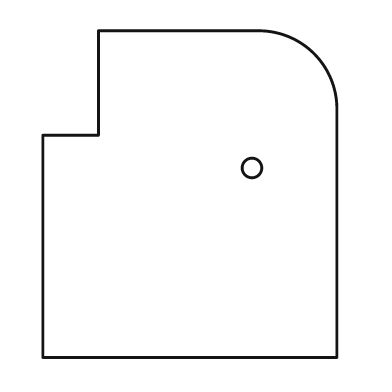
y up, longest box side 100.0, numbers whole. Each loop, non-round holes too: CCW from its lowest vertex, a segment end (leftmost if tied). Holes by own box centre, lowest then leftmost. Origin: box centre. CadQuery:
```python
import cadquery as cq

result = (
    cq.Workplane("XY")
    .moveTo(-45.0, -50.0)
    .lineTo(45.0, -50.0)
    .lineTo(45.0, 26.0)
    .threePointArc((38.0, 43.0), (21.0, 50.0))
    .lineTo(-28.0, 50.0)
    .lineTo(-28.0, 18.0)
    .lineTo(-45.0, 18.0)
    .close()
    .moveTo(19.0, 8.0)
    .circle(3.0)
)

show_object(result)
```